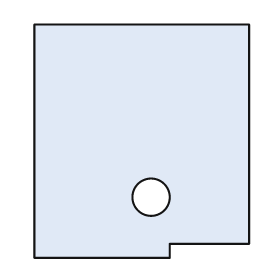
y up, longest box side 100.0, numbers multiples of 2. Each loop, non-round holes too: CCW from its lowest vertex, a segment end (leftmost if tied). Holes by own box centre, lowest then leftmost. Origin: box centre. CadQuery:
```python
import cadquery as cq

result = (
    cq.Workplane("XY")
    .moveTo(-46.0, -50.0)
    .lineTo(12.0, -50.0)
    .lineTo(12.0, -44.0)
    .lineTo(46.0, -44.0)
    .lineTo(46.0, 50.0)
    .lineTo(-46.0, 50.0)
    .close()
    .moveTo(4.0, -24.0)
    .circle(8.0)
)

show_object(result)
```